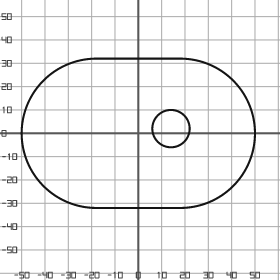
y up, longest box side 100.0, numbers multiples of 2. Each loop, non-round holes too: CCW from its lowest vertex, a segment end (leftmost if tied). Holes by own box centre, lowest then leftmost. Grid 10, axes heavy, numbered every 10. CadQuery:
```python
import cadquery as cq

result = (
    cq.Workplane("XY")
    .moveTo(-18.0, -32.0)
    .lineTo(18.0, -32.0)
    .threePointArc((50.0, 0.0), (18.0, 32.0))
    .lineTo(-18.0, 32.0)
    .threePointArc((-50.0, 0.0), (-18.0, -32.0))
    .close()
    .moveTo(14.0, 2.0)
    .circle(8.0)
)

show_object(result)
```